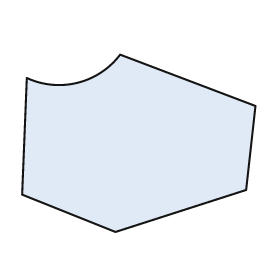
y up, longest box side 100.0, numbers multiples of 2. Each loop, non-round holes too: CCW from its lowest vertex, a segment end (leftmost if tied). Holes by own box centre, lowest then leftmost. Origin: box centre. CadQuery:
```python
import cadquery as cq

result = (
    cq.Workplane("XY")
    .moveTo(-10.0, -38.0)
    .lineTo(46.0, -20.0)
    .lineTo(50.0, 16.0)
    .lineTo(-8.0, 38.0)
    .threePointArc((-26.0, 26.0), (-48.0, 28.0))
    .lineTo(-50.0, -22.0)
    .close()
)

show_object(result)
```